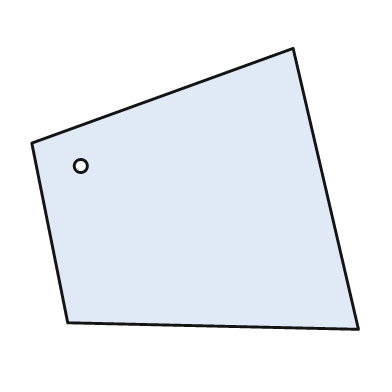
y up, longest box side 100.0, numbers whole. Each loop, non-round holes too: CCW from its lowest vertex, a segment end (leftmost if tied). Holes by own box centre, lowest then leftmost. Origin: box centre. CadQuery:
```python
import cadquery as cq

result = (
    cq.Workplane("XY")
    .moveTo(50.0, -43.0)
    .lineTo(30.0, 43.0)
    .lineTo(-50.0, 14.0)
    .lineTo(-39.0, -41.0)
    .close()
    .moveTo(-35.0, 7.0)
    .circle(2.0)
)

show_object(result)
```